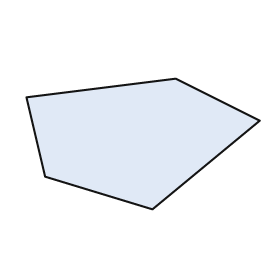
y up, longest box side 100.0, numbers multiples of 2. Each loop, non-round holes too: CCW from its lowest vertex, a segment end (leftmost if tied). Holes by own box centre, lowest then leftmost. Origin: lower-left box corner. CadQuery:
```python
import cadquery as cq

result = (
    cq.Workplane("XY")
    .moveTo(54.0, 0.0)
    .lineTo(100.0, 38.0)
    .lineTo(64.0, 56.0)
    .lineTo(0.0, 48.0)
    .lineTo(8.0, 14.0)
    .close()
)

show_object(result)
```